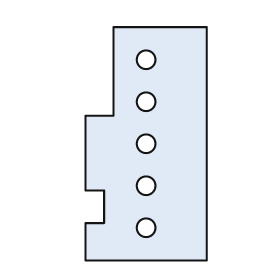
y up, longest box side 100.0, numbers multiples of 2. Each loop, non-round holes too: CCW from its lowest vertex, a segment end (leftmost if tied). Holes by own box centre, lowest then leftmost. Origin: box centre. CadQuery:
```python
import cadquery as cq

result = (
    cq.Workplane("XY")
    .moveTo(-26.0, -50.0)
    .lineTo(26.0, -50.0)
    .lineTo(26.0, 50.0)
    .lineTo(-14.0, 50.0)
    .lineTo(-14.0, 12.0)
    .lineTo(-26.0, 12.0)
    .lineTo(-26.0, -20.0)
    .lineTo(-18.0, -20.0)
    .lineTo(-18.0, -34.0)
    .lineTo(-26.0, -34.0)
    .close()
    .moveTo(0.0, -36.0)
    .circle(4.0)
    .moveTo(0.0, -18.0)
    .circle(4.0)
    .moveTo(0.0, 0.0)
    .circle(4.0)
    .moveTo(0.0, 18.0)
    .circle(4.0)
    .moveTo(0.0, 36.0)
    .circle(4.0)
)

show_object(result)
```